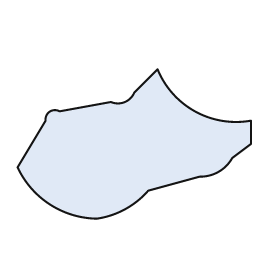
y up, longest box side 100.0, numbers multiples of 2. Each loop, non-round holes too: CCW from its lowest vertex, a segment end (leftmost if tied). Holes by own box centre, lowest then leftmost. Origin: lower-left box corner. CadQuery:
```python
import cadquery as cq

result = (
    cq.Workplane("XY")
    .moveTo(34.0, 0.0)
    .threePointArc((46.0, 4.0), (56.0, 12.0))
    .lineTo(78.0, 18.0)
    .threePointArc((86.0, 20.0), (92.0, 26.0))
    .lineTo(100.0, 32.0)
    .lineTo(100.0, 42.0)
    .threePointArc((76.0, 46.0), (60.0, 64.0))
    .lineTo(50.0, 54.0)
    .threePointArc((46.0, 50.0), (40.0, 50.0))
    .lineTo(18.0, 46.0)
    .threePointArc((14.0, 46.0), (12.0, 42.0))
    .lineTo(0.0, 22.0)
    .threePointArc((14.0, 6.0), (34.0, 0.0))
    .close()
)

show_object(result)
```